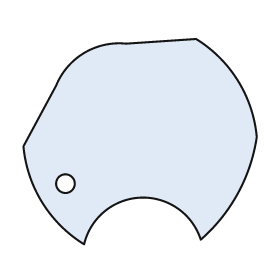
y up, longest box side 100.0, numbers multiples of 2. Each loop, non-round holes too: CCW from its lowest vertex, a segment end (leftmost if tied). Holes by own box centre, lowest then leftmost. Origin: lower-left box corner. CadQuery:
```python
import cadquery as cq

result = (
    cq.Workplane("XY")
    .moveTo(26.0, 0.0)
    .threePointArc((50.0, 20.0), (76.0, 2.0))
    .threePointArc((92.0, 22.0), (100.0, 46.0))
    .threePointArc((92.0, 70.0), (74.0, 88.0))
    .lineTo(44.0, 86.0)
    .threePointArc((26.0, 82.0), (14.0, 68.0))
    .lineTo(0.0, 42.0)
    .threePointArc((8.0, 18.0), (26.0, 0.0))
    .close()
    .moveTo(18.0, 26.0)
    .circle(4.0)
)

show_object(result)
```